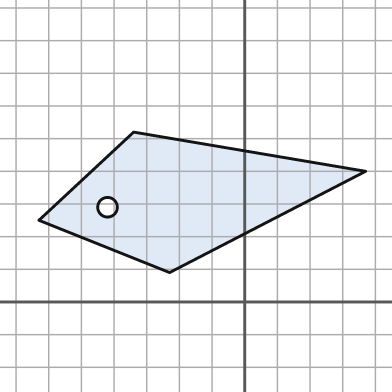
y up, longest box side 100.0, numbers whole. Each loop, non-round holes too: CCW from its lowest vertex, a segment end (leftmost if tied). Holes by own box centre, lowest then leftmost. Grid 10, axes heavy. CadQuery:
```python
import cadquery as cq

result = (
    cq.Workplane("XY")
    .moveTo(-23.0, 9.0)
    .lineTo(37.0, 40.0)
    .lineTo(-34.0, 52.0)
    .lineTo(-63.0, 25.0)
    .close()
    .moveTo(-42.0, 29.0)
    .circle(3.0)
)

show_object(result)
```